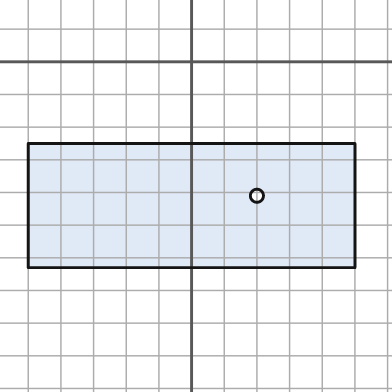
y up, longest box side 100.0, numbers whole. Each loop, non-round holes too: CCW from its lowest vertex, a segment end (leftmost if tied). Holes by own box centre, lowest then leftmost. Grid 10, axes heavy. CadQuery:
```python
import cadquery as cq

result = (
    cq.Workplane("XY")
    .moveTo(-50.0, -63.0)
    .lineTo(50.0, -63.0)
    .lineTo(50.0, -25.0)
    .lineTo(-50.0, -25.0)
    .close()
    .moveTo(20.0, -41.0)
    .circle(2.0)
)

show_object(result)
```